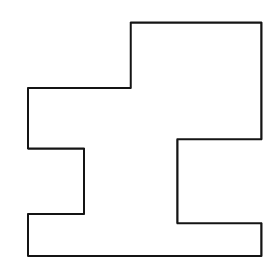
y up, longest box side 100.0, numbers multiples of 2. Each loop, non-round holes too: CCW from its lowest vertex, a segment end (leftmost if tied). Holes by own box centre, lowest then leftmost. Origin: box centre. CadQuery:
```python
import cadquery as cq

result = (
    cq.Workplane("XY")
    .moveTo(-50.0, -50.0)
    .lineTo(50.0, -50.0)
    .lineTo(50.0, -36.0)
    .lineTo(14.0, -36.0)
    .lineTo(14.0, 0.0)
    .lineTo(50.0, 0.0)
    .lineTo(50.0, 50.0)
    .lineTo(-6.0, 50.0)
    .lineTo(-6.0, 22.0)
    .lineTo(-50.0, 22.0)
    .lineTo(-50.0, -4.0)
    .lineTo(-26.0, -4.0)
    .lineTo(-26.0, -32.0)
    .lineTo(-50.0, -32.0)
    .close()
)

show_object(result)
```